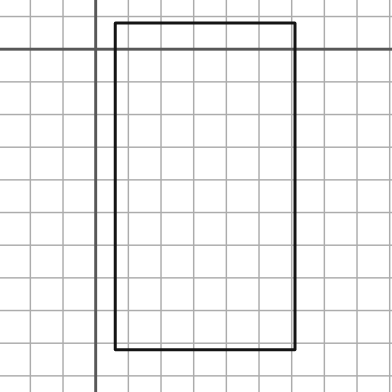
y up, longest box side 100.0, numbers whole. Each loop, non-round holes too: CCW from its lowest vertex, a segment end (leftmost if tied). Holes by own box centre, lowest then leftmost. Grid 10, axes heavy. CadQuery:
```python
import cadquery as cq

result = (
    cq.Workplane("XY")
    .moveTo(6.0, -92.0)
    .lineTo(61.0, -92.0)
    .lineTo(61.0, 8.0)
    .lineTo(6.0, 8.0)
    .close()
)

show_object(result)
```